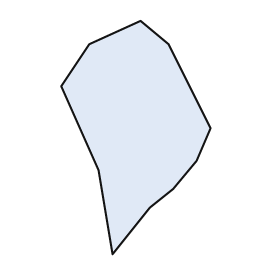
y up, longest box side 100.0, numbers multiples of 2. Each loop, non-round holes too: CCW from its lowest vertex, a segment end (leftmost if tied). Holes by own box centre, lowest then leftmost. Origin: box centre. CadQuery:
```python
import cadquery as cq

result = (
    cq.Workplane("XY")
    .moveTo(-10.0, -50.0)
    .lineTo(6.0, -30.0)
    .lineTo(16.0, -22.0)
    .lineTo(26.0, -10.0)
    .lineTo(32.0, 4.0)
    .lineTo(14.0, 40.0)
    .lineTo(2.0, 50.0)
    .lineTo(-20.0, 40.0)
    .lineTo(-32.0, 22.0)
    .lineTo(-16.0, -14.0)
    .close()
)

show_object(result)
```